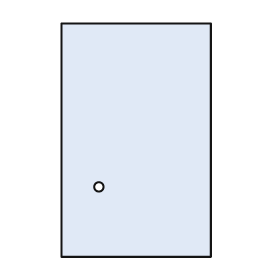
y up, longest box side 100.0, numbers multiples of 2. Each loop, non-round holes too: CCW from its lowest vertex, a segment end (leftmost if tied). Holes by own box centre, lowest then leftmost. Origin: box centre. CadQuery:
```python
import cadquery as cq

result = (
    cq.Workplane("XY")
    .moveTo(-32.0, -50.0)
    .lineTo(32.0, -50.0)
    .lineTo(32.0, 50.0)
    .lineTo(-32.0, 50.0)
    .close()
    .moveTo(-16.0, -20.0)
    .circle(2.0)
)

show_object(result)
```